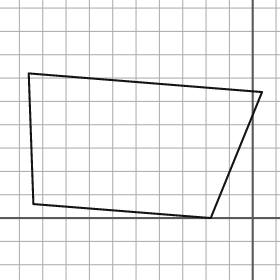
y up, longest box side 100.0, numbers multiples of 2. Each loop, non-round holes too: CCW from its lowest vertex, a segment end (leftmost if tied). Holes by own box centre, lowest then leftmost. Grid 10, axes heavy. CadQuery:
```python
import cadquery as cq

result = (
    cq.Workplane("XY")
    .moveTo(-18.0, 0.0)
    .lineTo(4.0, 54.0)
    .lineTo(-96.0, 62.0)
    .lineTo(-94.0, 6.0)
    .close()
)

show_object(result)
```